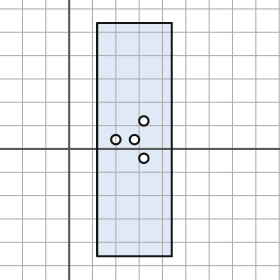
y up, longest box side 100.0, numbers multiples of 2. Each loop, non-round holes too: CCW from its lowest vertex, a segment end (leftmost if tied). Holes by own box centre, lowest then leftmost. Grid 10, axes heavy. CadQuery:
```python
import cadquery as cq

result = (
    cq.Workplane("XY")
    .moveTo(12.0, -46.0)
    .lineTo(44.0, -46.0)
    .lineTo(44.0, 54.0)
    .lineTo(12.0, 54.0)
    .close()
    .moveTo(32.0, -4.0)
    .circle(2.0)
    .moveTo(20.0, 4.0)
    .circle(2.0)
    .moveTo(28.0, 4.0)
    .circle(2.0)
    .moveTo(32.0, 12.0)
    .circle(2.0)
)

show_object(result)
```